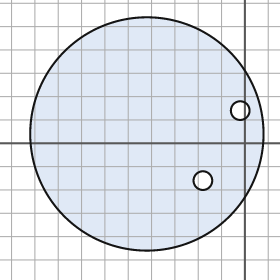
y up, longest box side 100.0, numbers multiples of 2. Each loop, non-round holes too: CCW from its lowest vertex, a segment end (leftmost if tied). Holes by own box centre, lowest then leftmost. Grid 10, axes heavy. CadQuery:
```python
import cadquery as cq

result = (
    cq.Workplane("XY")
    .moveTo(-42.0, 4.0)
    .circle(50.0)
    .moveTo(-18.0, -16.0)
    .circle(4.0)
    .moveTo(-2.0, 14.0)
    .circle(4.0)
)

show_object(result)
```